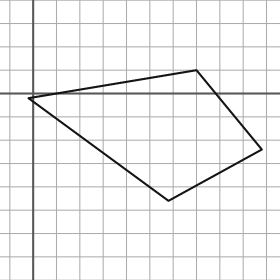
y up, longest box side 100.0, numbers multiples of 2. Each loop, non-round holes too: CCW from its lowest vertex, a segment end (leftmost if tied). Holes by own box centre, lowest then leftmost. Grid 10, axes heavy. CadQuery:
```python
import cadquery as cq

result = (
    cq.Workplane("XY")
    .moveTo(58.0, -46.0)
    .lineTo(98.0, -24.0)
    .lineTo(70.0, 10.0)
    .lineTo(-2.0, -2.0)
    .close()
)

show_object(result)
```